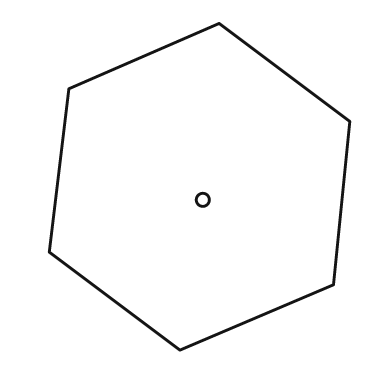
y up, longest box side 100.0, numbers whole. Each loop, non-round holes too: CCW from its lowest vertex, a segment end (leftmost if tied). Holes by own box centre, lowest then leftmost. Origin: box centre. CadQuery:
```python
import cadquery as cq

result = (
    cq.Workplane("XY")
    .moveTo(-6.0, -50.0)
    .lineTo(41.0, -30.0)
    .lineTo(46.0, 20.0)
    .lineTo(6.0, 50.0)
    .lineTo(-40.0, 30.0)
    .lineTo(-46.0, -20.0)
    .close()
    .moveTo(1.0, -4.0)
    .circle(2.0)
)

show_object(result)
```